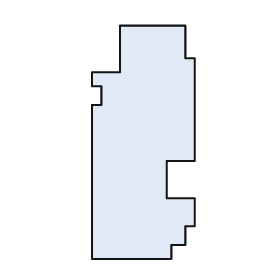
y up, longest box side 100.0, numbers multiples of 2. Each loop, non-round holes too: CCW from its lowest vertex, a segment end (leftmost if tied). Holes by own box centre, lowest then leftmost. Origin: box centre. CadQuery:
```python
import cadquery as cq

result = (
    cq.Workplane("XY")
    .moveTo(-22.0, -50.0)
    .lineTo(12.0, -50.0)
    .lineTo(12.0, -44.0)
    .lineTo(18.0, -44.0)
    .lineTo(18.0, -36.0)
    .lineTo(22.0, -36.0)
    .lineTo(22.0, -24.0)
    .lineTo(10.0, -24.0)
    .lineTo(10.0, -8.0)
    .lineTo(22.0, -8.0)
    .lineTo(22.0, 36.0)
    .lineTo(18.0, 36.0)
    .lineTo(18.0, 50.0)
    .lineTo(-10.0, 50.0)
    .lineTo(-10.0, 30.0)
    .lineTo(-22.0, 30.0)
    .lineTo(-22.0, 24.0)
    .lineTo(-18.0, 24.0)
    .lineTo(-18.0, 16.0)
    .lineTo(-22.0, 16.0)
    .close()
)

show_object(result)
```